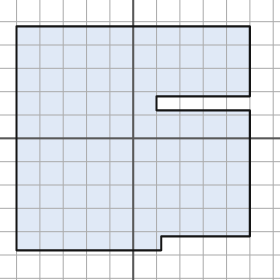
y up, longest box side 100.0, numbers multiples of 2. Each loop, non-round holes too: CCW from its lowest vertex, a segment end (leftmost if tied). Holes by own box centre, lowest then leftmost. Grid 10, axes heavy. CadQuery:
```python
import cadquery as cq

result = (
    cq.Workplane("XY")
    .moveTo(-50.0, -48.0)
    .lineTo(12.0, -48.0)
    .lineTo(12.0, -42.0)
    .lineTo(50.0, -42.0)
    .lineTo(50.0, 12.0)
    .lineTo(10.0, 12.0)
    .lineTo(10.0, 18.0)
    .lineTo(50.0, 18.0)
    .lineTo(50.0, 48.0)
    .lineTo(-50.0, 48.0)
    .close()
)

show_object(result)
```